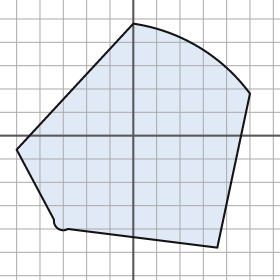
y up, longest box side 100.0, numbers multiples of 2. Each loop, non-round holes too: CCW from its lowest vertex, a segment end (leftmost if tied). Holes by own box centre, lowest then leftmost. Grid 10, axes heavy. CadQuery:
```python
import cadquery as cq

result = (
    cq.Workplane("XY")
    .moveTo(36.0, -48.0)
    .lineTo(50.0, 18.0)
    .threePointArc((28.0, 38.0), (0.0, 48.0))
    .lineTo(-50.0, -6.0)
    .lineTo(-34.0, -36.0)
    .threePointArc((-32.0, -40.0), (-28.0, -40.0))
    .close()
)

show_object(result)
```